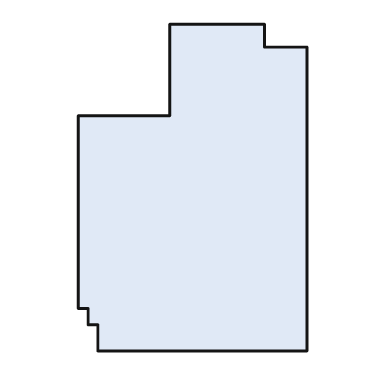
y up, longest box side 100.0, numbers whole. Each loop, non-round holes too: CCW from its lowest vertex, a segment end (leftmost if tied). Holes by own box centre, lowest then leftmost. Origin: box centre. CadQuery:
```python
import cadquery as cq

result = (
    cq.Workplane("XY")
    .moveTo(-29.0, -50.0)
    .lineTo(35.0, -50.0)
    .lineTo(35.0, 43.0)
    .lineTo(22.0, 43.0)
    .lineTo(22.0, 50.0)
    .lineTo(-7.0, 50.0)
    .lineTo(-7.0, 22.0)
    .lineTo(-35.0, 22.0)
    .lineTo(-35.0, -37.0)
    .lineTo(-32.0, -37.0)
    .lineTo(-32.0, -42.0)
    .lineTo(-29.0, -42.0)
    .close()
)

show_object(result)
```